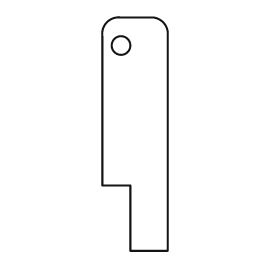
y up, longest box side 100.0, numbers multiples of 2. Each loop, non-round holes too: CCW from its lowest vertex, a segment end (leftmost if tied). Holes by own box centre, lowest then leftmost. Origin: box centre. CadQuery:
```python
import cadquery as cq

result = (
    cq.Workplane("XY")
    .moveTo(-2.0, -50.0)
    .lineTo(14.0, -50.0)
    .lineTo(14.0, 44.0)
    .threePointArc((12.0, 48.0), (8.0, 50.0))
    .lineTo(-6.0, 50.0)
    .threePointArc((-12.0, 48.0), (-14.0, 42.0))
    .lineTo(-14.0, -22.0)
    .lineTo(-2.0, -22.0)
    .close()
    .moveTo(-6.0, 38.0)
    .circle(4.0)
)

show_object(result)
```